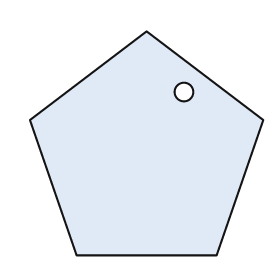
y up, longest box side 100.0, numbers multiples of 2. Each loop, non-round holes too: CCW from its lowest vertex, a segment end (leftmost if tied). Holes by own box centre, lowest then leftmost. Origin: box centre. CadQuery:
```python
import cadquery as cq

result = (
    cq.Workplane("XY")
    .moveTo(-30.0, -48.0)
    .lineTo(30.0, -48.0)
    .lineTo(50.0, 10.0)
    .lineTo(0.0, 48.0)
    .lineTo(-50.0, 10.0)
    .close()
    .moveTo(16.0, 22.0)
    .circle(4.0)
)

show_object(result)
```